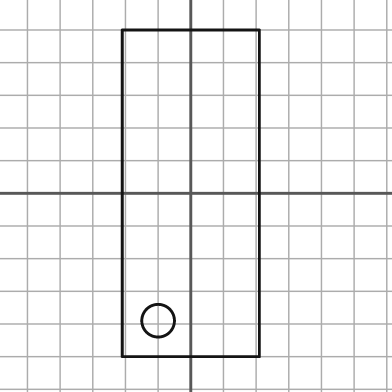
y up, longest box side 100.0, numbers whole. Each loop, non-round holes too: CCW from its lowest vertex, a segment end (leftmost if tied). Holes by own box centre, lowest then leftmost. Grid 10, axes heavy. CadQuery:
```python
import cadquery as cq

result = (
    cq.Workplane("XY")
    .moveTo(-21.0, -50.0)
    .lineTo(21.0, -50.0)
    .lineTo(21.0, 50.0)
    .lineTo(-21.0, 50.0)
    .close()
    .moveTo(-10.0, -39.0)
    .circle(5.0)
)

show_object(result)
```